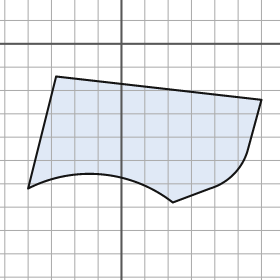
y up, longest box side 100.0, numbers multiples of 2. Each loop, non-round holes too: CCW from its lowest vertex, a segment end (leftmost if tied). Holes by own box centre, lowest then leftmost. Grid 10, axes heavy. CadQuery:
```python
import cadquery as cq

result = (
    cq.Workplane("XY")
    .moveTo(22.0, -68.0)
    .lineTo(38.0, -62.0)
    .threePointArc((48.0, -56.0), (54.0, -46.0))
    .lineTo(60.0, -24.0)
    .lineTo(-28.0, -14.0)
    .lineTo(-40.0, -62.0)
    .threePointArc((-8.0, -56.0), (22.0, -68.0))
    .close()
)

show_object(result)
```